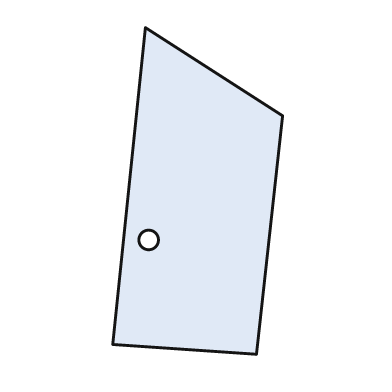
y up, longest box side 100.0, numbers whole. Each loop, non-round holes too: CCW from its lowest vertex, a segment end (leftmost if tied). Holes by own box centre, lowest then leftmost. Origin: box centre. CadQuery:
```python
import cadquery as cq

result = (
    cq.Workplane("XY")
    .moveTo(18.0, -50.0)
    .lineTo(26.0, 23.0)
    .lineTo(-16.0, 50.0)
    .lineTo(-26.0, -47.0)
    .close()
    .moveTo(-15.0, -15.0)
    .circle(3.0)
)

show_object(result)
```